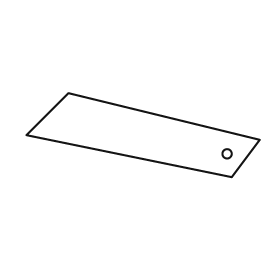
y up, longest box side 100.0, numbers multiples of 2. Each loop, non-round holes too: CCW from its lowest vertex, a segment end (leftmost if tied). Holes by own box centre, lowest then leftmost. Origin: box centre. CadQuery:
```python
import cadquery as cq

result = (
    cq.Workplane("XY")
    .moveTo(38.0, -18.0)
    .lineTo(50.0, -2.0)
    .lineTo(-32.0, 18.0)
    .lineTo(-50.0, 0.0)
    .close()
    .moveTo(36.0, -8.0)
    .circle(2.0)
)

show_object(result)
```